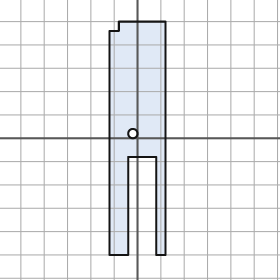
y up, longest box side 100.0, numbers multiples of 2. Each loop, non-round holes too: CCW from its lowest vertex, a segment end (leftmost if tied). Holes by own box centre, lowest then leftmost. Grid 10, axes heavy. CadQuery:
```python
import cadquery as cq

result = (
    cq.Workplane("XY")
    .moveTo(-12.0, -50.0)
    .lineTo(-4.0, -50.0)
    .lineTo(-4.0, -8.0)
    .lineTo(8.0, -8.0)
    .lineTo(8.0, -50.0)
    .lineTo(12.0, -50.0)
    .lineTo(12.0, 50.0)
    .lineTo(-8.0, 50.0)
    .lineTo(-8.0, 46.0)
    .lineTo(-12.0, 46.0)
    .close()
    .moveTo(-2.0, 2.0)
    .circle(2.0)
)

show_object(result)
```